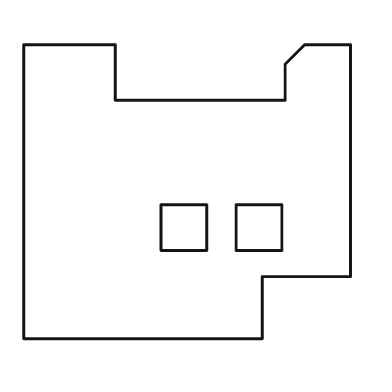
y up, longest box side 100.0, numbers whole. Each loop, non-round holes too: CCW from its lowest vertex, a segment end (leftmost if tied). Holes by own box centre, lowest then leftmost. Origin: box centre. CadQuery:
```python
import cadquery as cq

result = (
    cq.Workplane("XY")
    .moveTo(-50.0, -45.0)
    .lineTo(23.0, -45.0)
    .lineTo(23.0, -26.0)
    .lineTo(50.0, -26.0)
    .lineTo(50.0, 45.0)
    .lineTo(36.0, 45.0)
    .lineTo(30.0, 39.0)
    .lineTo(30.0, 28.0)
    .lineTo(-22.0, 28.0)
    .lineTo(-22.0, 45.0)
    .lineTo(-50.0, 45.0)
    .close()
    .moveTo(-8.0, -18.0)
    .lineTo(6.0, -18.0)
    .lineTo(6.0, -4.0)
    .lineTo(-8.0, -4.0)
    .close()
    .moveTo(15.0, -18.0)
    .lineTo(29.0, -18.0)
    .lineTo(29.0, -4.0)
    .lineTo(15.0, -4.0)
    .close()
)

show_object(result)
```